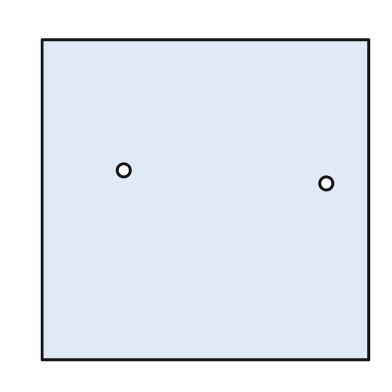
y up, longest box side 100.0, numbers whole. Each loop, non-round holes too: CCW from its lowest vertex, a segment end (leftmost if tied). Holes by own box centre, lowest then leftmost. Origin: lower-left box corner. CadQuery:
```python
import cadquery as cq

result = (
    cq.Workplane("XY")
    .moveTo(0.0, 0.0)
    .lineTo(100.0, 0.0)
    .lineTo(100.0, 98.0)
    .lineTo(0.0, 98.0)
    .close()
    .moveTo(87.0, 54.0)
    .circle(2.0)
    .moveTo(25.0, 58.0)
    .circle(2.0)
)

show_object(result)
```